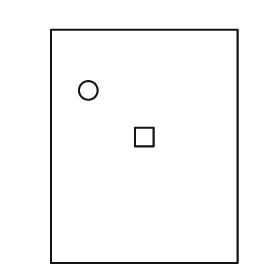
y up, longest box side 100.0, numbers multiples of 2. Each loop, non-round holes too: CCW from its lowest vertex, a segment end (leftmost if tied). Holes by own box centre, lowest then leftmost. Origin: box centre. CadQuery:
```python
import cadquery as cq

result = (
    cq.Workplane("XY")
    .moveTo(-40.0, -50.0)
    .lineTo(40.0, -50.0)
    .lineTo(40.0, 50.0)
    .lineTo(-40.0, 50.0)
    .close()
    .moveTo(-4.0, 0.0)
    .lineTo(4.0, 0.0)
    .lineTo(4.0, 8.0)
    .lineTo(-4.0, 8.0)
    .close()
    .moveTo(-24.0, 24.0)
    .circle(4.0)
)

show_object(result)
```